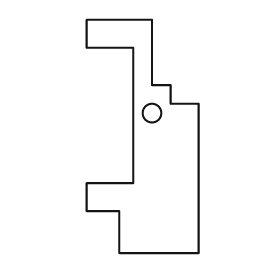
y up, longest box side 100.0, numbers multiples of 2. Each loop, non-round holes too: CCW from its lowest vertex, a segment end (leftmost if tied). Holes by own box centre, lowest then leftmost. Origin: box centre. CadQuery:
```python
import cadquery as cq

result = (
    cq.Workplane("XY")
    .moveTo(-10.0, -50.0)
    .lineTo(24.0, -50.0)
    .lineTo(24.0, 14.0)
    .lineTo(12.0, 14.0)
    .lineTo(12.0, 22.0)
    .lineTo(4.0, 22.0)
    .lineTo(4.0, 50.0)
    .lineTo(-24.0, 50.0)
    .lineTo(-24.0, 38.0)
    .lineTo(-4.0, 38.0)
    .lineTo(-4.0, -20.0)
    .lineTo(-24.0, -20.0)
    .lineTo(-24.0, -32.0)
    .lineTo(-10.0, -32.0)
    .close()
    .moveTo(4.0, 10.0)
    .circle(4.0)
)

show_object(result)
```